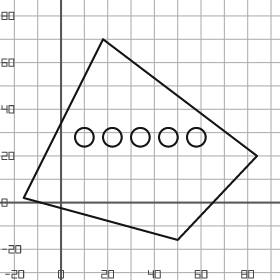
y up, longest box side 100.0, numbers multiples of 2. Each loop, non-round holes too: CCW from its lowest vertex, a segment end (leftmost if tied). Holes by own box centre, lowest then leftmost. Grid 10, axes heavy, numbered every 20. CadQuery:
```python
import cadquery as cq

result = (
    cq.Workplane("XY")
    .moveTo(50.0, -16.0)
    .lineTo(84.0, 20.0)
    .lineTo(18.0, 70.0)
    .lineTo(-16.0, 2.0)
    .close()
    .moveTo(10.0, 28.0)
    .circle(4.0)
    .moveTo(22.0, 28.0)
    .circle(4.0)
    .moveTo(34.0, 28.0)
    .circle(4.0)
    .moveTo(46.0, 28.0)
    .circle(4.0)
    .moveTo(58.0, 28.0)
    .circle(4.0)
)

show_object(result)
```